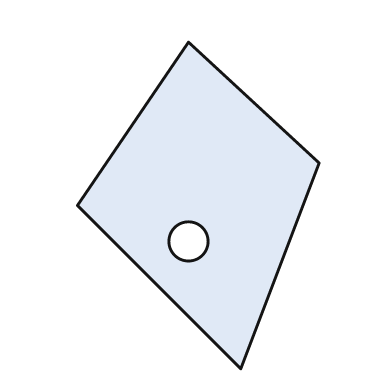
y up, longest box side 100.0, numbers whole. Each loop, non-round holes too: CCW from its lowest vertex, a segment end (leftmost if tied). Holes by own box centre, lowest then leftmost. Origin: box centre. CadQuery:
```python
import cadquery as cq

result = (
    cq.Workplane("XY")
    .moveTo(13.0, -50.0)
    .lineTo(37.0, 13.0)
    .lineTo(-3.0, 50.0)
    .lineTo(-37.0, 0.0)
    .close()
    .moveTo(-3.0, -11.0)
    .circle(6.0)
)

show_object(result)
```